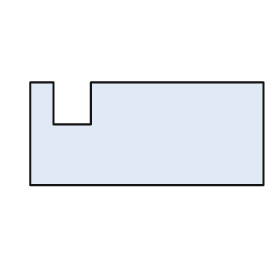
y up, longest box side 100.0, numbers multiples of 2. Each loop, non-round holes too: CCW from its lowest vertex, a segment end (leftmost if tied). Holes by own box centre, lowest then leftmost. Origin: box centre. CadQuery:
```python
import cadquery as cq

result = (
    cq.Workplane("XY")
    .moveTo(-50.0, -22.0)
    .lineTo(50.0, -22.0)
    .lineTo(50.0, 22.0)
    .lineTo(-24.0, 22.0)
    .lineTo(-24.0, 4.0)
    .lineTo(-40.0, 4.0)
    .lineTo(-40.0, 22.0)
    .lineTo(-50.0, 22.0)
    .close()
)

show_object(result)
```